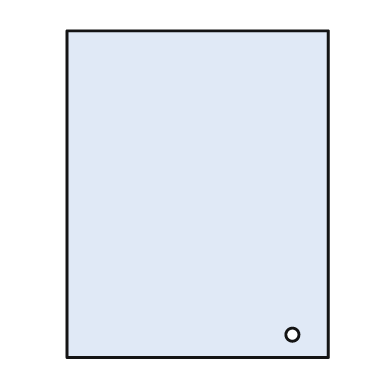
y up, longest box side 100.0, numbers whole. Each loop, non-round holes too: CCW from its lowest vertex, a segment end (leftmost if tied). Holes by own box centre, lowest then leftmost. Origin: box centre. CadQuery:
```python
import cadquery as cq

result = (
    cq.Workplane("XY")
    .moveTo(-40.0, -50.0)
    .lineTo(40.0, -50.0)
    .lineTo(40.0, 50.0)
    .lineTo(-40.0, 50.0)
    .close()
    .moveTo(29.0, -43.0)
    .circle(2.0)
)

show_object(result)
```